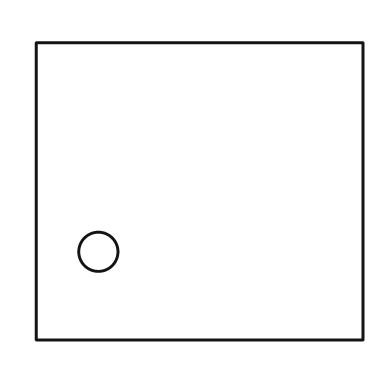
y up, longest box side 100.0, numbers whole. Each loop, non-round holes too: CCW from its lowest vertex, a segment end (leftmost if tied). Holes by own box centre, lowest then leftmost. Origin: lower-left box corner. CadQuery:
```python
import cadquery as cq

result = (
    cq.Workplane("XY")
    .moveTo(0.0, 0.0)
    .lineTo(100.0, 0.0)
    .lineTo(100.0, 91.0)
    .lineTo(0.0, 91.0)
    .close()
    .moveTo(19.0, 27.0)
    .circle(6.0)
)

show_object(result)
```